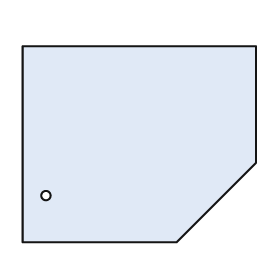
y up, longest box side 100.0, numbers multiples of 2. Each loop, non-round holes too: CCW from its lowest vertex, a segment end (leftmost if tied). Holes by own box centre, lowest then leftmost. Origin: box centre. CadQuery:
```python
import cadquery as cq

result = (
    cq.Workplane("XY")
    .moveTo(-50.0, -42.0)
    .lineTo(16.0, -42.0)
    .lineTo(50.0, -8.0)
    .lineTo(50.0, 42.0)
    .lineTo(-50.0, 42.0)
    .close()
    .moveTo(-40.0, -22.0)
    .circle(2.0)
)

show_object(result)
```